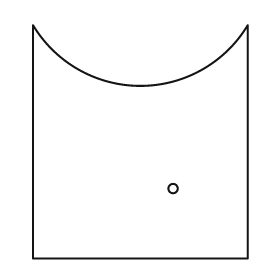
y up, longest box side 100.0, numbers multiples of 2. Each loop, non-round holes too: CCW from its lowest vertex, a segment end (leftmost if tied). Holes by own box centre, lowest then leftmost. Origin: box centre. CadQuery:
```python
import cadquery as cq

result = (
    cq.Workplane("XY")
    .moveTo(-46.0, -50.0)
    .lineTo(46.0, -50.0)
    .lineTo(46.0, 50.0)
    .threePointArc((0.0, 24.0), (-46.0, 50.0))
    .close()
    .moveTo(14.0, -20.0)
    .circle(2.0)
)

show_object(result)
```